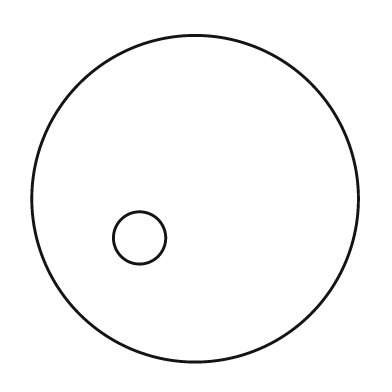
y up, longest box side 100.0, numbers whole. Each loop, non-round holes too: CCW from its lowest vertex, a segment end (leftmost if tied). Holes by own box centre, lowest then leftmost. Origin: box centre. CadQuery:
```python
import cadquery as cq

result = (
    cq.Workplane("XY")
    .moveTo(0.0, 0.0)
    .circle(50.0)
    .moveTo(-17.0, -12.0)
    .circle(8.0)
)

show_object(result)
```